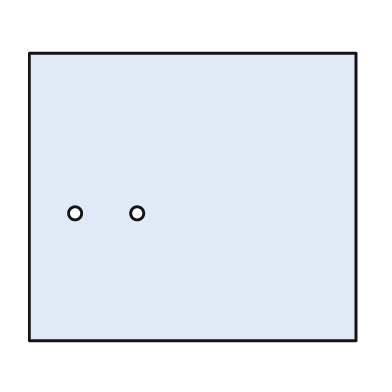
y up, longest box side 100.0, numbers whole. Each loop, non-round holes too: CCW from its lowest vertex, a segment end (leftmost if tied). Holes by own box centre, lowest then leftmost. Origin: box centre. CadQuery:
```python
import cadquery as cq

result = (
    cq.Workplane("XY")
    .moveTo(-50.0, -44.0)
    .lineTo(50.0, -44.0)
    .lineTo(50.0, 44.0)
    .lineTo(-50.0, 44.0)
    .close()
    .moveTo(-36.0, -5.0)
    .circle(2.0)
    .moveTo(-17.0, -5.0)
    .circle(2.0)
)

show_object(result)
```